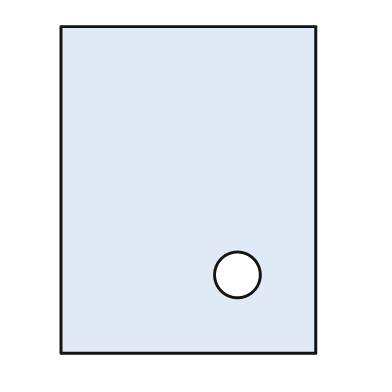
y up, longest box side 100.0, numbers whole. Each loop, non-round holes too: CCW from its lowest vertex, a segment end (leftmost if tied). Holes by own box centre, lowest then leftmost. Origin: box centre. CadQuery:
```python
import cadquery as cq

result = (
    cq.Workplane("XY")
    .moveTo(-39.0, -50.0)
    .lineTo(39.0, -50.0)
    .lineTo(39.0, 50.0)
    .lineTo(-39.0, 50.0)
    .close()
    .moveTo(15.0, -26.0)
    .circle(7.0)
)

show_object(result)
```